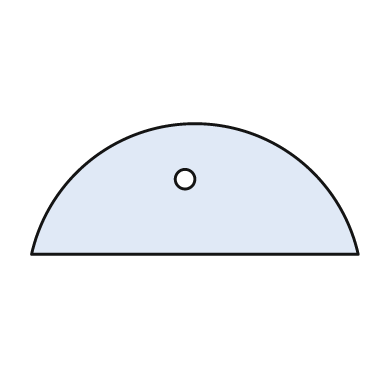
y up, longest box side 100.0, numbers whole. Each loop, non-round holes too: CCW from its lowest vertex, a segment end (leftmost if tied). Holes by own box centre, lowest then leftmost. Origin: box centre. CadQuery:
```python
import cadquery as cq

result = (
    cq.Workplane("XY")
    .moveTo(-50.0, -20.0)
    .lineTo(50.0, -20.0)
    .threePointArc((0.0, 20.0), (-50.0, -20.0))
    .close()
    .moveTo(-3.0, 3.0)
    .circle(3.0)
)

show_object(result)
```